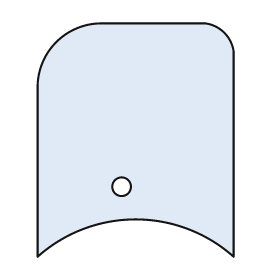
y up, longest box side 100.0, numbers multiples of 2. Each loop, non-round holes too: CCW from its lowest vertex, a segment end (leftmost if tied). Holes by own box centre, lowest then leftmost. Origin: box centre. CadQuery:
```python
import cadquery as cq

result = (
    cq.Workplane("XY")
    .moveTo(-42.0, -50.0)
    .threePointArc((0.0, -34.0), (42.0, -50.0))
    .lineTo(42.0, 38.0)
    .threePointArc((38.0, 46.0), (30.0, 50.0))
    .lineTo(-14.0, 50.0)
    .threePointArc((-34.0, 42.0), (-42.0, 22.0))
    .close()
    .moveTo(-6.0, -20.0)
    .circle(4.0)
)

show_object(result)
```